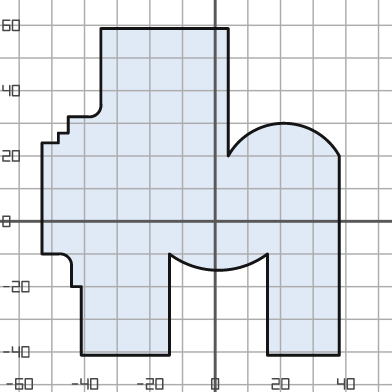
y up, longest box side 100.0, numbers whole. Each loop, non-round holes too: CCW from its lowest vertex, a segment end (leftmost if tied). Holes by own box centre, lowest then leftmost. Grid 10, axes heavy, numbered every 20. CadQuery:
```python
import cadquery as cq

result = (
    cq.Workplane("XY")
    .moveTo(-41.0, -41.0)
    .lineTo(-14.0, -41.0)
    .lineTo(-14.0, -10.0)
    .threePointArc((1.0, -15.0), (16.0, -10.0))
    .lineTo(16.0, -41.0)
    .lineTo(38.0, -41.0)
    .lineTo(38.0, 20.0)
    .threePointArc((21.0, 30.0), (4.0, 20.0))
    .lineTo(4.0, 59.0)
    .lineTo(-35.0, 59.0)
    .lineTo(-35.0, 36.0)
    .threePointArc((-36.0, 33.0), (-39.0, 32.0))
    .lineTo(-45.0, 32.0)
    .lineTo(-45.0, 27.0)
    .lineTo(-48.0, 27.0)
    .lineTo(-48.0, 24.0)
    .lineTo(-53.0, 24.0)
    .lineTo(-53.0, -10.0)
    .lineTo(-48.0, -10.0)
    .threePointArc((-45.0, -11.0), (-44.0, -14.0))
    .lineTo(-44.0, -20.0)
    .lineTo(-41.0, -20.0)
    .close()
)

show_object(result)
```